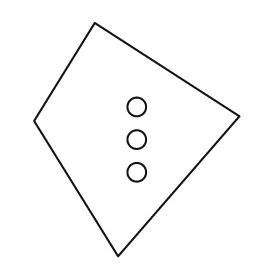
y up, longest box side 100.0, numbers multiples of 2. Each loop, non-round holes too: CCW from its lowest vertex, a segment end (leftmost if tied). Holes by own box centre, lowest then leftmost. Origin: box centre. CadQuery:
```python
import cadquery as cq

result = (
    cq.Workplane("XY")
    .moveTo(-8.0, -50.0)
    .lineTo(44.0, 10.0)
    .lineTo(-18.0, 50.0)
    .lineTo(-44.0, 8.0)
    .close()
    .moveTo(0.0, -14.0)
    .circle(4.0)
    .moveTo(0.0, 0.0)
    .circle(4.0)
    .moveTo(0.0, 14.0)
    .circle(4.0)
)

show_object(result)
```